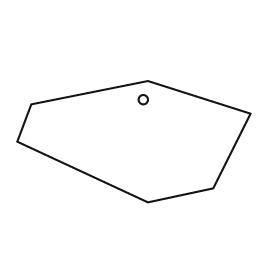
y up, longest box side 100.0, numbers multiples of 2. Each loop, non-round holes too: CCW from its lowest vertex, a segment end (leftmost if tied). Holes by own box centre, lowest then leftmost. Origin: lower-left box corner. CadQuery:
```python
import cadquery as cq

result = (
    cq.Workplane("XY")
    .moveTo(56.0, 0.0)
    .lineTo(84.0, 6.0)
    .lineTo(100.0, 38.0)
    .lineTo(56.0, 52.0)
    .lineTo(6.0, 42.0)
    .lineTo(0.0, 26.0)
    .close()
    .moveTo(54.0, 44.0)
    .circle(2.0)
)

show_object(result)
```